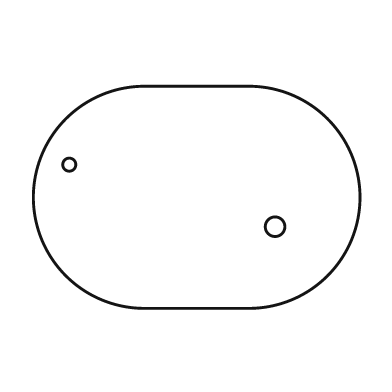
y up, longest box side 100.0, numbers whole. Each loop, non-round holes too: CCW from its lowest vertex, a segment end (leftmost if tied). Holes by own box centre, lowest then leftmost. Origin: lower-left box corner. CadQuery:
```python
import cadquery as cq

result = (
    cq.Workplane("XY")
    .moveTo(34.0, 0.0)
    .lineTo(66.0, 0.0)
    .threePointArc((100.0, 34.0), (66.0, 68.0))
    .lineTo(34.0, 68.0)
    .threePointArc((0.0, 34.0), (34.0, 0.0))
    .close()
    .moveTo(74.0, 25.0)
    .circle(3.0)
    .moveTo(11.0, 44.0)
    .circle(2.0)
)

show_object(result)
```